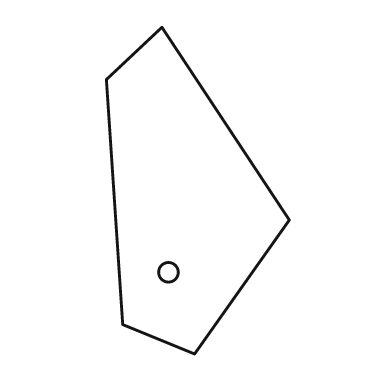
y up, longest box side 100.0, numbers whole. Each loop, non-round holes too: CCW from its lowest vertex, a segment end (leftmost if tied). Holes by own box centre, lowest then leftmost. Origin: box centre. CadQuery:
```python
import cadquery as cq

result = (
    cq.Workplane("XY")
    .moveTo(-1.0, -50.0)
    .lineTo(28.0, -9.0)
    .lineTo(-11.0, 50.0)
    .lineTo(-28.0, 34.0)
    .lineTo(-23.0, -41.0)
    .close()
    .moveTo(-9.0, -25.0)
    .circle(3.0)
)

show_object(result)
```